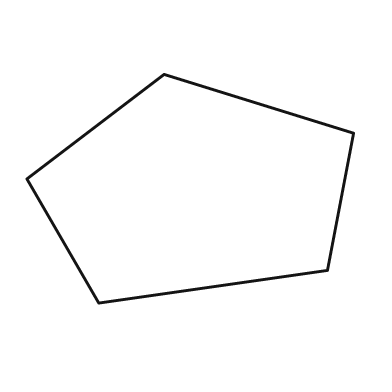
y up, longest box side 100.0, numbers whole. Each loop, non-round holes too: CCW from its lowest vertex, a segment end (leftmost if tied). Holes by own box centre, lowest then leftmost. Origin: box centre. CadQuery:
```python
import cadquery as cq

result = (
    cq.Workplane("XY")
    .moveTo(-28.0, -35.0)
    .lineTo(42.0, -25.0)
    .lineTo(50.0, 17.0)
    .lineTo(-8.0, 35.0)
    .lineTo(-50.0, 3.0)
    .close()
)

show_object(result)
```